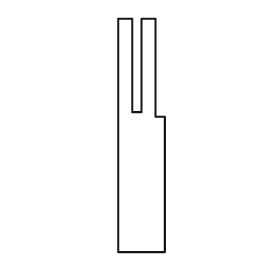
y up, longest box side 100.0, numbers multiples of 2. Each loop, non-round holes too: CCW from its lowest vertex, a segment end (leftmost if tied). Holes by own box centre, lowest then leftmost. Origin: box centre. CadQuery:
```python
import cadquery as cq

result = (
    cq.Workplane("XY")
    .moveTo(-10.0, -50.0)
    .lineTo(10.0, -50.0)
    .lineTo(10.0, 8.0)
    .lineTo(6.0, 8.0)
    .lineTo(6.0, 50.0)
    .lineTo(0.0, 50.0)
    .lineTo(0.0, 10.0)
    .lineTo(-4.0, 10.0)
    .lineTo(-4.0, 50.0)
    .lineTo(-10.0, 50.0)
    .close()
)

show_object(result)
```